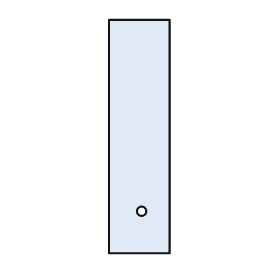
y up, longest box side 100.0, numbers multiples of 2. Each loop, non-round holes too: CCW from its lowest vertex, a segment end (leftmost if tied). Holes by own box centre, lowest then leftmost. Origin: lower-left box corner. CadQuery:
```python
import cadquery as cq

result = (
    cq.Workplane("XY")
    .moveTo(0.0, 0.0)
    .lineTo(26.0, 0.0)
    .lineTo(26.0, 100.0)
    .lineTo(0.0, 100.0)
    .close()
    .moveTo(14.0, 18.0)
    .circle(2.0)
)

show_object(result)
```